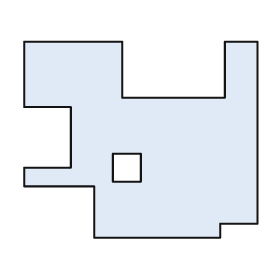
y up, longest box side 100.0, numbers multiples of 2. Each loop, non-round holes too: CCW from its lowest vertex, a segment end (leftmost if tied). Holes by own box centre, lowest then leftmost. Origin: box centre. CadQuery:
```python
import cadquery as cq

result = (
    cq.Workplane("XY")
    .moveTo(-20.0, -42.0)
    .lineTo(34.0, -42.0)
    .lineTo(34.0, -36.0)
    .lineTo(50.0, -36.0)
    .lineTo(50.0, 42.0)
    .lineTo(36.0, 42.0)
    .lineTo(36.0, 18.0)
    .lineTo(-8.0, 18.0)
    .lineTo(-8.0, 42.0)
    .lineTo(-50.0, 42.0)
    .lineTo(-50.0, 14.0)
    .lineTo(-30.0, 14.0)
    .lineTo(-30.0, -12.0)
    .lineTo(-50.0, -12.0)
    .lineTo(-50.0, -20.0)
    .lineTo(-20.0, -20.0)
    .close()
    .moveTo(-12.0, -18.0)
    .lineTo(0.0, -18.0)
    .lineTo(0.0, -6.0)
    .lineTo(-12.0, -6.0)
    .close()
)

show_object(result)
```